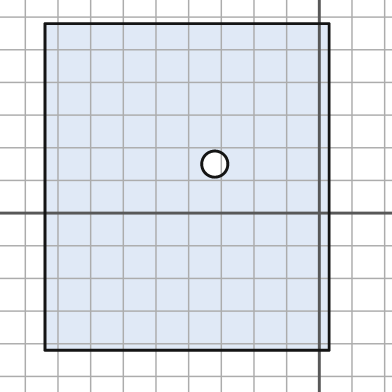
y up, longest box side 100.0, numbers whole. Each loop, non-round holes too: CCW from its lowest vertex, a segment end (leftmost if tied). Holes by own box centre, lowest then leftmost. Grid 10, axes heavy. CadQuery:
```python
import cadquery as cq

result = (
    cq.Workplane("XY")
    .moveTo(-84.0, -42.0)
    .lineTo(3.0, -42.0)
    .lineTo(3.0, 58.0)
    .lineTo(-84.0, 58.0)
    .close()
    .moveTo(-32.0, 15.0)
    .circle(4.0)
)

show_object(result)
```